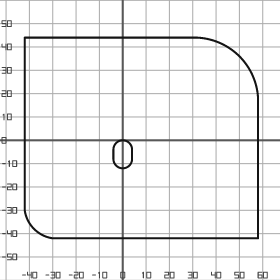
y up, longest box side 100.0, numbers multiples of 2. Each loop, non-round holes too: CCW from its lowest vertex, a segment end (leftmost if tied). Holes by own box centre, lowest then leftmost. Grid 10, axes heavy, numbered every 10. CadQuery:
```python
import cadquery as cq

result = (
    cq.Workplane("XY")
    .moveTo(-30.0, -42.0)
    .lineTo(58.0, -42.0)
    .lineTo(58.0, 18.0)
    .threePointArc((50.0, 36.0), (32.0, 44.0))
    .lineTo(-42.0, 44.0)
    .lineTo(-42.0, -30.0)
    .threePointArc((-38.0, -38.0), (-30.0, -42.0))
    .close()
    .moveTo(-4.0, -8.0)
    .threePointArc((0.0, -12.0), (4.0, -8.0))
    .lineTo(4.0, -4.0)
    .threePointArc((0.0, 0.0), (-4.0, -4.0))
    .close()
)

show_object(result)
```